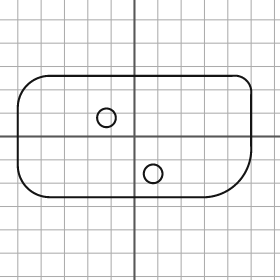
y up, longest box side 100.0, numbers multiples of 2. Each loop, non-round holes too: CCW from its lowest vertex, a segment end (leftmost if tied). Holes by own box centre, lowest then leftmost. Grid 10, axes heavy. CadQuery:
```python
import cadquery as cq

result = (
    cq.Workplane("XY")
    .moveTo(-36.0, -26.0)
    .lineTo(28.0, -26.0)
    .threePointArc((44.0, -20.0), (50.0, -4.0))
    .lineTo(50.0, 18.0)
    .threePointArc((48.0, 24.0), (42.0, 26.0))
    .lineTo(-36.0, 26.0)
    .threePointArc((-46.0, 22.0), (-50.0, 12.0))
    .lineTo(-50.0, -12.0)
    .threePointArc((-46.0, -22.0), (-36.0, -26.0))
    .close()
    .moveTo(8.0, -16.0)
    .circle(4.0)
    .moveTo(-12.0, 8.0)
    .circle(4.0)
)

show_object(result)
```